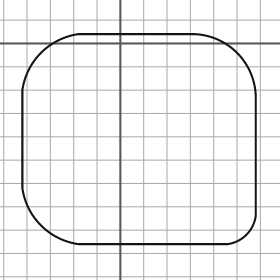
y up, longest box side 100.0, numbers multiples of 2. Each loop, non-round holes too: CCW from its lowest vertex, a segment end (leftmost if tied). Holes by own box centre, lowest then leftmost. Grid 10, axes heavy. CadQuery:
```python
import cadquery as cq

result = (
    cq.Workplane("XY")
    .moveTo(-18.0, -86.0)
    .lineTo(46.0, -86.0)
    .threePointArc((54.0, -82.0), (58.0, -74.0))
    .lineTo(58.0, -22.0)
    .threePointArc((50.0, -4.0), (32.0, 4.0))
    .lineTo(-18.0, 4.0)
    .threePointArc((-34.0, -4.0), (-42.0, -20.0))
    .lineTo(-42.0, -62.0)
    .threePointArc((-34.0, -78.0), (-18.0, -86.0))
    .close()
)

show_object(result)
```